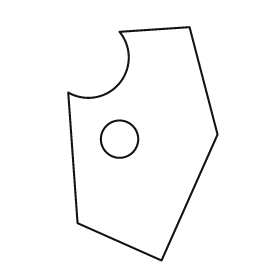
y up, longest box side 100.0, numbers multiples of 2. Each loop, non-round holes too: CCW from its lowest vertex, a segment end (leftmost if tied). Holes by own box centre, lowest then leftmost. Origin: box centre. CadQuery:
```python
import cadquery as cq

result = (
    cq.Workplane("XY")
    .moveTo(8.0, -50.0)
    .lineTo(32.0, 4.0)
    .lineTo(20.0, 50.0)
    .lineTo(-10.0, 48.0)
    .threePointArc((-10.0, 26.0), (-32.0, 22.0))
    .lineTo(-28.0, -34.0)
    .close()
    .moveTo(-10.0, 2.0)
    .circle(8.0)
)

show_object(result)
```